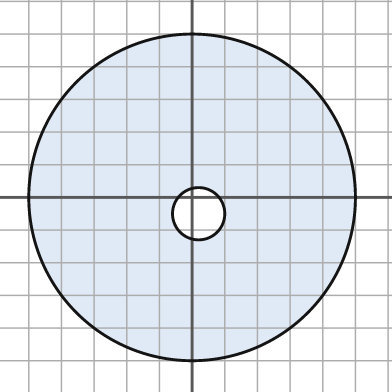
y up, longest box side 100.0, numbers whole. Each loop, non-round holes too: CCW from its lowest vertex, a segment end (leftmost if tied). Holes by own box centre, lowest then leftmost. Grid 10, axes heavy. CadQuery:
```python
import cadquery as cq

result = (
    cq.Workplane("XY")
    .moveTo(0.0, 0.0)
    .circle(50.0)
    .moveTo(2.0, -5.0)
    .circle(8.0)
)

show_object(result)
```